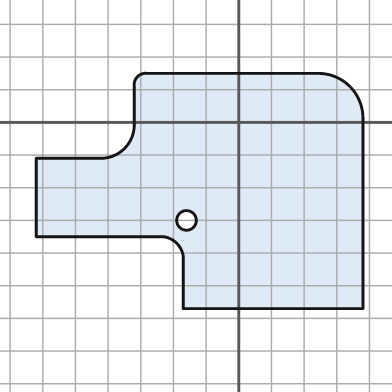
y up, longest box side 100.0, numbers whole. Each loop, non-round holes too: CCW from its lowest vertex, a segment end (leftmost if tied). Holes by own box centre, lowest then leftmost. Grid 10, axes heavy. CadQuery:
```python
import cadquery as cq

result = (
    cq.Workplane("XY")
    .moveTo(-17.0, -57.0)
    .lineTo(38.0, -57.0)
    .lineTo(38.0, 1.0)
    .threePointArc((34.0, 11.0), (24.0, 15.0))
    .lineTo(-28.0, 15.0)
    .threePointArc((-31.0, 14.0), (-32.0, 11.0))
    .lineTo(-32.0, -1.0)
    .threePointArc((-35.0, -8.0), (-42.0, -11.0))
    .lineTo(-62.0, -11.0)
    .lineTo(-62.0, -35.0)
    .lineTo(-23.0, -35.0)
    .threePointArc((-19.0, -37.0), (-17.0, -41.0))
    .close()
    .moveTo(-16.0, -30.0)
    .circle(3.0)
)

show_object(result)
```